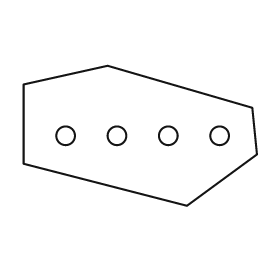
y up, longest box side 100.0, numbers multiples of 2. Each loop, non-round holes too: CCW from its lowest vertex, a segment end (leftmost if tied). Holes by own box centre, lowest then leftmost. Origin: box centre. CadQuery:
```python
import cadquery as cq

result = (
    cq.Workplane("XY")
    .moveTo(20.0, -30.0)
    .lineTo(50.0, -8.0)
    .lineTo(48.0, 12.0)
    .lineTo(-14.0, 30.0)
    .lineTo(-50.0, 22.0)
    .lineTo(-50.0, -12.0)
    .close()
    .moveTo(-32.0, 0.0)
    .circle(4.0)
    .moveTo(-10.0, 0.0)
    .circle(4.0)
    .moveTo(12.0, 0.0)
    .circle(4.0)
    .moveTo(34.0, 0.0)
    .circle(4.0)
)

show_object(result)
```